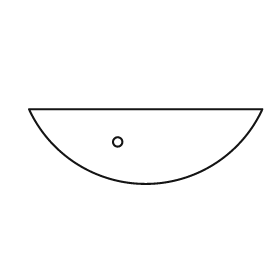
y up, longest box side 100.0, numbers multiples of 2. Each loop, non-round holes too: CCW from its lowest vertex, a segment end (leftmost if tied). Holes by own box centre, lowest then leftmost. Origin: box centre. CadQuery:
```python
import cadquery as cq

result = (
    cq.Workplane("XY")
    .moveTo(-50.0, 16.0)
    .threePointArc((0.0, -16.0), (50.0, 16.0))
    .close()
    .moveTo(-12.0, 2.0)
    .circle(2.0)
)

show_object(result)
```